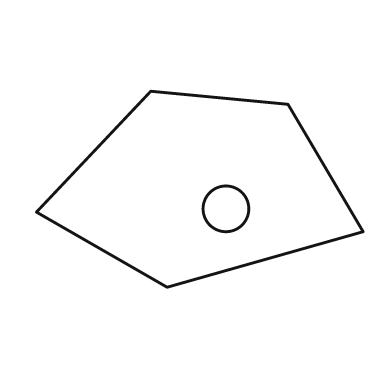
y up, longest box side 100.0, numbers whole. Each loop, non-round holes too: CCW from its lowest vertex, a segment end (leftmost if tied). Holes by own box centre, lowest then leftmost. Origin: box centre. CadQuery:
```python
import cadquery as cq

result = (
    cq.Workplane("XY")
    .moveTo(-10.0, -30.0)
    .lineTo(50.0, -13.0)
    .lineTo(27.0, 26.0)
    .lineTo(-15.0, 30.0)
    .lineTo(-50.0, -7.0)
    .close()
    .moveTo(8.0, -6.0)
    .circle(7.0)
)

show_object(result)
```